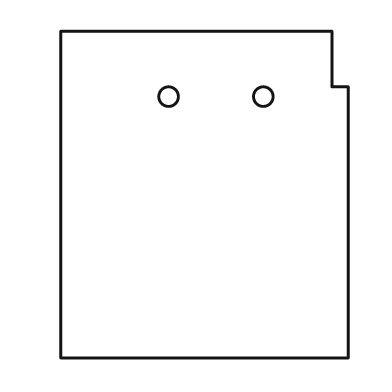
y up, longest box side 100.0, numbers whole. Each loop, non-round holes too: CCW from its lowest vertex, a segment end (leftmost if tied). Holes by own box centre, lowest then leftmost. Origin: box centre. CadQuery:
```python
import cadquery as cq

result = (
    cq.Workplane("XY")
    .moveTo(-44.0, -50.0)
    .lineTo(44.0, -50.0)
    .lineTo(44.0, 33.0)
    .lineTo(39.0, 33.0)
    .lineTo(39.0, 50.0)
    .lineTo(-44.0, 50.0)
    .close()
    .moveTo(-11.0, 30.0)
    .circle(3.0)
    .moveTo(18.0, 30.0)
    .circle(3.0)
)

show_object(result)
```